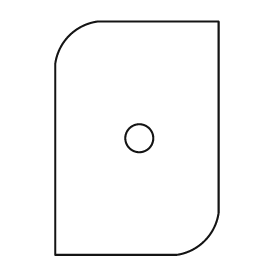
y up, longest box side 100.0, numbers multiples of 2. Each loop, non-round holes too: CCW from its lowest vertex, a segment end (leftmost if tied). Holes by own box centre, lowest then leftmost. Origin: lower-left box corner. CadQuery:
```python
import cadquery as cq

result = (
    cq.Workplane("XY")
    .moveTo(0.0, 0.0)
    .lineTo(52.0, 0.0)
    .threePointArc((64.0, 6.0), (70.0, 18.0))
    .lineTo(70.0, 100.0)
    .lineTo(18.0, 100.0)
    .threePointArc((6.0, 94.0), (0.0, 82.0))
    .close()
    .moveTo(36.0, 50.0)
    .circle(6.0)
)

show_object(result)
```